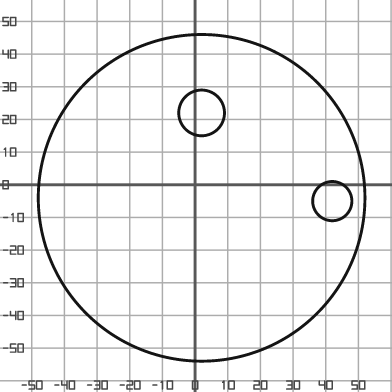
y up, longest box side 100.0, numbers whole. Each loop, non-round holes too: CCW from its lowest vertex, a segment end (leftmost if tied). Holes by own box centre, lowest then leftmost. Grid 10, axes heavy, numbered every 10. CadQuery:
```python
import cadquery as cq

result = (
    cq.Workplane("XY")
    .moveTo(2.0, -4.0)
    .circle(50.0)
    .moveTo(42.0, -5.0)
    .circle(6.0)
    .moveTo(2.0, 22.0)
    .circle(7.0)
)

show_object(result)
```